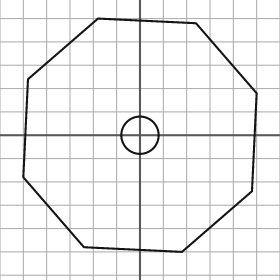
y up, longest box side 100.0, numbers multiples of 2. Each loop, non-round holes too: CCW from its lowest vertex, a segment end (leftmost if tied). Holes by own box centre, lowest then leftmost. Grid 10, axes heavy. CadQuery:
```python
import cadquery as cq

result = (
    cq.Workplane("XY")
    .moveTo(18.0, -50.0)
    .lineTo(48.0, -24.0)
    .lineTo(50.0, 18.0)
    .lineTo(24.0, 48.0)
    .lineTo(-18.0, 50.0)
    .lineTo(-48.0, 24.0)
    .lineTo(-50.0, -18.0)
    .lineTo(-24.0, -48.0)
    .close()
    .moveTo(0.0, 0.0)
    .circle(8.0)
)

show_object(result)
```